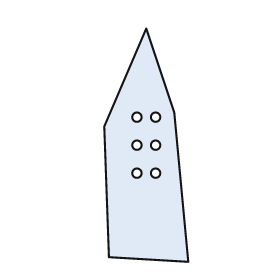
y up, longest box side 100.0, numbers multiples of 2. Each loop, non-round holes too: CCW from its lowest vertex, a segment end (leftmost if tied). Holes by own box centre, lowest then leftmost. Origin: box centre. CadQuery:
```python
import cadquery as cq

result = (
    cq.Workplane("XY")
    .moveTo(18.0, -50.0)
    .lineTo(12.0, 14.0)
    .lineTo(0.0, 50.0)
    .lineTo(-18.0, 8.0)
    .lineTo(-16.0, -48.0)
    .close()
    .moveTo(-4.0, -12.0)
    .circle(2.0)
    .moveTo(4.0, -12.0)
    .circle(2.0)
    .moveTo(-4.0, 0.0)
    .circle(2.0)
    .moveTo(4.0, 0.0)
    .circle(2.0)
    .moveTo(-4.0, 12.0)
    .circle(2.0)
    .moveTo(4.0, 12.0)
    .circle(2.0)
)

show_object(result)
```